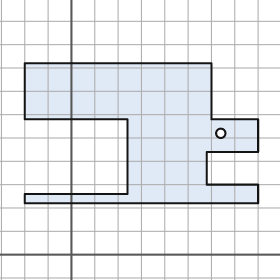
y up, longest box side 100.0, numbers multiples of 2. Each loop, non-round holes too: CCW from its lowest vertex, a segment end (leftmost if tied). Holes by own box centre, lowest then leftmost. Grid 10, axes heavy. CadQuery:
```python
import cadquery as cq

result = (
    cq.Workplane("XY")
    .moveTo(-20.0, 22.0)
    .lineTo(80.0, 22.0)
    .lineTo(80.0, 30.0)
    .lineTo(58.0, 30.0)
    .lineTo(58.0, 44.0)
    .lineTo(80.0, 44.0)
    .lineTo(80.0, 58.0)
    .lineTo(60.0, 58.0)
    .lineTo(60.0, 82.0)
    .lineTo(-20.0, 82.0)
    .lineTo(-20.0, 58.0)
    .lineTo(24.0, 58.0)
    .lineTo(24.0, 26.0)
    .lineTo(-20.0, 26.0)
    .close()
    .moveTo(64.0, 52.0)
    .circle(2.0)
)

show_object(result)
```